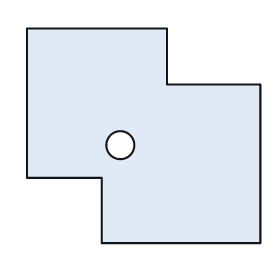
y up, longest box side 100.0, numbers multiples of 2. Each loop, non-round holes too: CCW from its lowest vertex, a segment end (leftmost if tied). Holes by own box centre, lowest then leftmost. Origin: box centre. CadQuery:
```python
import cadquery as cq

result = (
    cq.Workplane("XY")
    .moveTo(-18.0, -46.0)
    .lineTo(50.0, -46.0)
    .lineTo(50.0, 22.0)
    .lineTo(10.0, 22.0)
    .lineTo(10.0, 46.0)
    .lineTo(-50.0, 46.0)
    .lineTo(-50.0, -18.0)
    .lineTo(-18.0, -18.0)
    .close()
    .moveTo(-10.0, -4.0)
    .circle(6.0)
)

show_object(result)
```